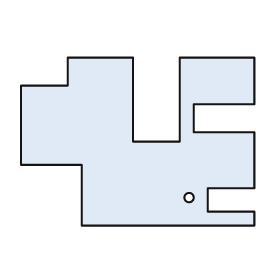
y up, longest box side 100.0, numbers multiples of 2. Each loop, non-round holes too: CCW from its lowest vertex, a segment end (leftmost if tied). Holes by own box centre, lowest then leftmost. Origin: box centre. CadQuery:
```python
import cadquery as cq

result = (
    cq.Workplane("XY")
    .moveTo(-24.0, -36.0)
    .lineTo(50.0, -36.0)
    .lineTo(50.0, -30.0)
    .lineTo(30.0, -30.0)
    .lineTo(30.0, -20.0)
    .lineTo(50.0, -20.0)
    .lineTo(50.0, 4.0)
    .lineTo(24.0, 4.0)
    .lineTo(24.0, 16.0)
    .lineTo(50.0, 16.0)
    .lineTo(50.0, 36.0)
    .lineTo(18.0, 36.0)
    .lineTo(18.0, 0.0)
    .lineTo(-2.0, 0.0)
    .lineTo(-2.0, 36.0)
    .lineTo(-30.0, 36.0)
    .lineTo(-30.0, 24.0)
    .lineTo(-50.0, 24.0)
    .lineTo(-50.0, -10.0)
    .lineTo(-24.0, -10.0)
    .close()
    .moveTo(22.0, -24.0)
    .circle(2.0)
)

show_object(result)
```